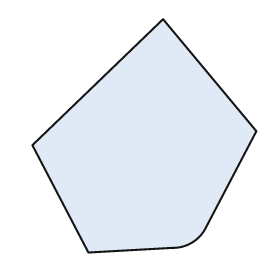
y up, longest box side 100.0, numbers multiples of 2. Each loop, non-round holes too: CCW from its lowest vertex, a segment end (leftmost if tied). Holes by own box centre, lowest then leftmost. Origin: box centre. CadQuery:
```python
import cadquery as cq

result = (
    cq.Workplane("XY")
    .moveTo(-24.0, -50.0)
    .lineTo(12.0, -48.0)
    .threePointArc((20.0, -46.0), (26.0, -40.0))
    .lineTo(48.0, 2.0)
    .lineTo(8.0, 50.0)
    .lineTo(-48.0, -4.0)
    .close()
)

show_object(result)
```